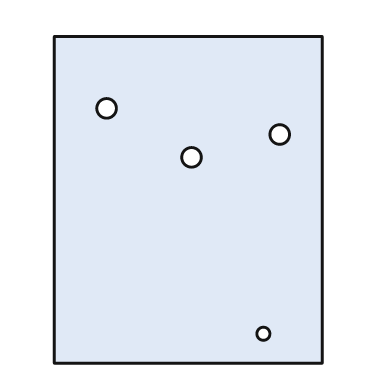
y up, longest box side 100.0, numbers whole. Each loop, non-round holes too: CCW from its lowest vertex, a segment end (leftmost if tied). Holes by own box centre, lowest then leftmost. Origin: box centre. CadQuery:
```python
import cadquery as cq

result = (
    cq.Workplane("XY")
    .moveTo(-41.0, -50.0)
    .lineTo(41.0, -50.0)
    .lineTo(41.0, 50.0)
    .lineTo(-41.0, 50.0)
    .close()
    .moveTo(23.0, -41.0)
    .circle(2.0)
    .moveTo(1.0, 13.0)
    .circle(3.0)
    .moveTo(28.0, 20.0)
    .circle(3.0)
    .moveTo(-25.0, 28.0)
    .circle(3.0)
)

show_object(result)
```